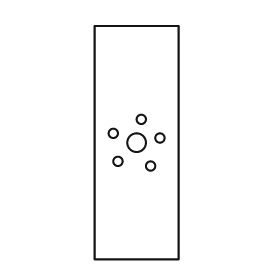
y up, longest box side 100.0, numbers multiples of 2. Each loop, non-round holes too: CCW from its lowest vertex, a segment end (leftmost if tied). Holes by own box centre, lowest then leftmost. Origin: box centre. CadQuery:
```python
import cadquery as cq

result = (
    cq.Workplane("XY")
    .moveTo(-18.0, -50.0)
    .lineTo(18.0, -50.0)
    .lineTo(18.0, 50.0)
    .lineTo(-18.0, 50.0)
    .close()
    .moveTo(6.0, -10.0)
    .circle(2.0)
    .moveTo(-8.0, -8.0)
    .circle(2.0)
    .moveTo(0.0, 0.0)
    .circle(4.0)
    .moveTo(10.0, 2.0)
    .circle(2.0)
    .moveTo(-10.0, 4.0)
    .circle(2.0)
    .moveTo(2.0, 10.0)
    .circle(2.0)
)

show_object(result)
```